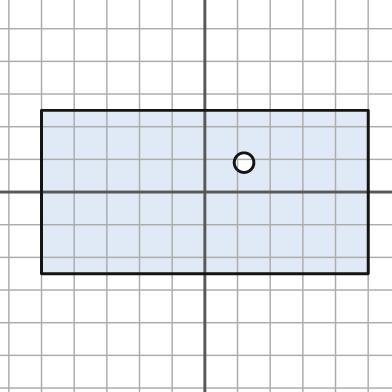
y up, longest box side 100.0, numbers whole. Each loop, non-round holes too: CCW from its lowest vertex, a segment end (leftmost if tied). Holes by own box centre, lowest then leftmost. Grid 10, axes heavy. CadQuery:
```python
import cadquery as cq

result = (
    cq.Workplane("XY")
    .moveTo(-50.0, -25.0)
    .lineTo(50.0, -25.0)
    .lineTo(50.0, 25.0)
    .lineTo(-50.0, 25.0)
    .close()
    .moveTo(12.0, 9.0)
    .circle(3.0)
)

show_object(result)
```